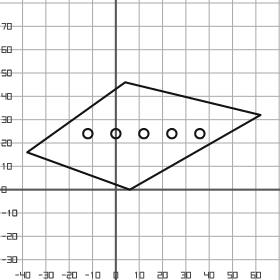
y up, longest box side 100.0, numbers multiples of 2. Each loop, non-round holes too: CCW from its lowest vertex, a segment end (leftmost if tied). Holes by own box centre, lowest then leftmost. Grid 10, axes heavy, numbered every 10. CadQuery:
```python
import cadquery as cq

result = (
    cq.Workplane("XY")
    .moveTo(6.0, 0.0)
    .lineTo(62.0, 32.0)
    .lineTo(4.0, 46.0)
    .lineTo(-38.0, 16.0)
    .close()
    .moveTo(-12.0, 24.0)
    .circle(2.0)
    .moveTo(0.0, 24.0)
    .circle(2.0)
    .moveTo(12.0, 24.0)
    .circle(2.0)
    .moveTo(24.0, 24.0)
    .circle(2.0)
    .moveTo(36.0, 24.0)
    .circle(2.0)
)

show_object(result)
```